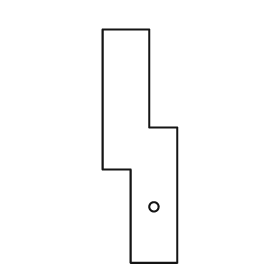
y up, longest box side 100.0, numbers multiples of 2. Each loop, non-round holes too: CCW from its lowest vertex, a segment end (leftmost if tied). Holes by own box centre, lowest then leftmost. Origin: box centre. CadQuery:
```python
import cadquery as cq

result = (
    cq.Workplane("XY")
    .moveTo(-4.0, -50.0)
    .lineTo(16.0, -50.0)
    .lineTo(16.0, 8.0)
    .lineTo(4.0, 8.0)
    .lineTo(4.0, 50.0)
    .lineTo(-16.0, 50.0)
    .lineTo(-16.0, -10.0)
    .lineTo(-4.0, -10.0)
    .close()
    .moveTo(6.0, -26.0)
    .circle(2.0)
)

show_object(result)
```